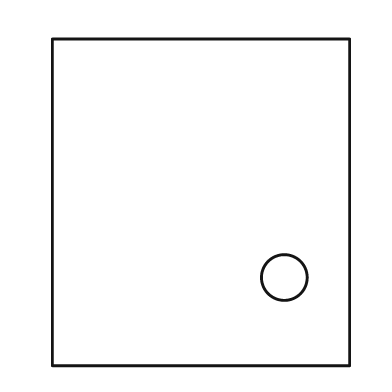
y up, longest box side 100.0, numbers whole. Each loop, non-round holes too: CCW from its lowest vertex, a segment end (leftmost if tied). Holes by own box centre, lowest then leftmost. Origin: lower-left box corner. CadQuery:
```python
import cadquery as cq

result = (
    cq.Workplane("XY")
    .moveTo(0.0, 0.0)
    .lineTo(91.0, 0.0)
    .lineTo(91.0, 100.0)
    .lineTo(0.0, 100.0)
    .close()
    .moveTo(71.0, 27.0)
    .circle(7.0)
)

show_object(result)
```